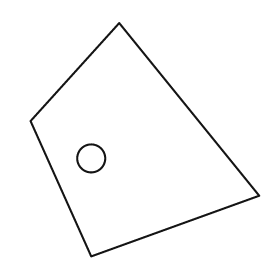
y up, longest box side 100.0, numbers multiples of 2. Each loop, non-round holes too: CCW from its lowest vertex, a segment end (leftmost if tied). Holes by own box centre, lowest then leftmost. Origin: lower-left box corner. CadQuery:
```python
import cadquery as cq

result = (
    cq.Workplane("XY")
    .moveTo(26.0, 0.0)
    .lineTo(98.0, 26.0)
    .lineTo(38.0, 100.0)
    .lineTo(0.0, 58.0)
    .close()
    .moveTo(26.0, 42.0)
    .circle(6.0)
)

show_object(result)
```